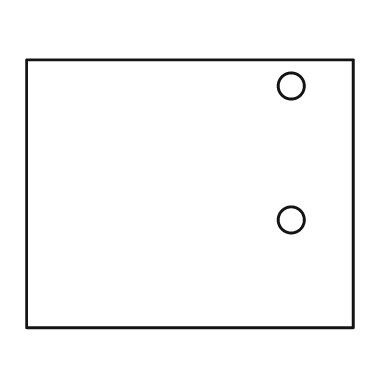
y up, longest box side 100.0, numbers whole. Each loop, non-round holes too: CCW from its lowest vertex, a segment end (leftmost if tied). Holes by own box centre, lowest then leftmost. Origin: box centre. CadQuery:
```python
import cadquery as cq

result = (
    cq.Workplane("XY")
    .moveTo(-50.0, -41.0)
    .lineTo(50.0, -41.0)
    .lineTo(50.0, 41.0)
    .lineTo(-50.0, 41.0)
    .close()
    .moveTo(31.0, -8.0)
    .circle(4.0)
    .moveTo(31.0, 33.0)
    .circle(4.0)
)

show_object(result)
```